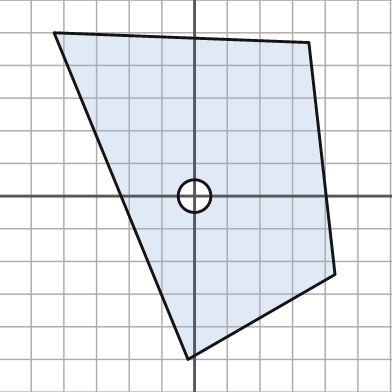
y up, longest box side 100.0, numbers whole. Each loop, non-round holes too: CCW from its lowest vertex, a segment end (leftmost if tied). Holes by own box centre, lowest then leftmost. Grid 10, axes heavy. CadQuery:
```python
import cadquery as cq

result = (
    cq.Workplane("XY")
    .moveTo(-2.0, -50.0)
    .lineTo(43.0, -24.0)
    .lineTo(35.0, 47.0)
    .lineTo(-43.0, 50.0)
    .close()
    .moveTo(0.0, 0.0)
    .circle(5.0)
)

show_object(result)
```